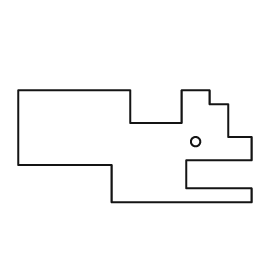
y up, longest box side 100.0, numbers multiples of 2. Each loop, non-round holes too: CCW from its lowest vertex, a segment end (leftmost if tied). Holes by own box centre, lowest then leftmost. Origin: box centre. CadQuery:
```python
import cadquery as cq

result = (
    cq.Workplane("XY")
    .moveTo(-10.0, -24.0)
    .lineTo(50.0, -24.0)
    .lineTo(50.0, -18.0)
    .lineTo(22.0, -18.0)
    .lineTo(22.0, -6.0)
    .lineTo(50.0, -6.0)
    .lineTo(50.0, 4.0)
    .lineTo(40.0, 4.0)
    .lineTo(40.0, 18.0)
    .lineTo(32.0, 18.0)
    .lineTo(32.0, 24.0)
    .lineTo(20.0, 24.0)
    .lineTo(20.0, 10.0)
    .lineTo(-2.0, 10.0)
    .lineTo(-2.0, 24.0)
    .lineTo(-50.0, 24.0)
    .lineTo(-50.0, -8.0)
    .lineTo(-10.0, -8.0)
    .close()
    .moveTo(26.0, 2.0)
    .circle(2.0)
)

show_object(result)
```